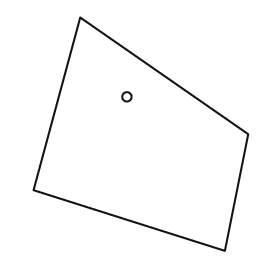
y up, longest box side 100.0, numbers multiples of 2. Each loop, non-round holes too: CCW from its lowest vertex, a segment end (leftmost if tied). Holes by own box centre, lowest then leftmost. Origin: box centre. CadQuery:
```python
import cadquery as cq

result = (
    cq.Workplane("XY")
    .moveTo(36.0, -50.0)
    .lineTo(46.0, 0.0)
    .lineTo(-26.0, 50.0)
    .lineTo(-46.0, -24.0)
    .close()
    .moveTo(-6.0, 16.0)
    .circle(2.0)
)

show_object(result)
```